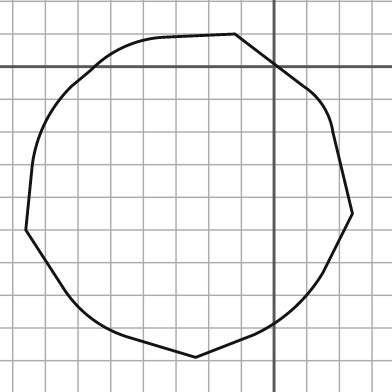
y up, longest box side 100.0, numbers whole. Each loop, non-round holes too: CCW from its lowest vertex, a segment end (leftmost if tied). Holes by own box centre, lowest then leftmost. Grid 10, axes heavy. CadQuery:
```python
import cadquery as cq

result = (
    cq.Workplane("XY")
    .moveTo(-24.0, -89.0)
    .lineTo(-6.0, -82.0)
    .threePointArc((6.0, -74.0), (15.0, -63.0))
    .lineTo(24.0, -45.0)
    .lineTo(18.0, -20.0)
    .threePointArc((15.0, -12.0), (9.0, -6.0))
    .lineTo(-12.0, 10.0)
    .lineTo(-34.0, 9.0)
    .threePointArc((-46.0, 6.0), (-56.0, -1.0))
    .lineTo(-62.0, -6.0)
    .threePointArc((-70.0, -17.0), (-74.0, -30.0))
    .lineTo(-76.0, -50.0)
    .lineTo(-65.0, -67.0)
    .threePointArc((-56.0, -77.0), (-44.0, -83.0))
    .close()
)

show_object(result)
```